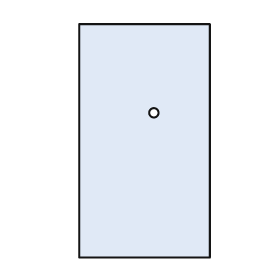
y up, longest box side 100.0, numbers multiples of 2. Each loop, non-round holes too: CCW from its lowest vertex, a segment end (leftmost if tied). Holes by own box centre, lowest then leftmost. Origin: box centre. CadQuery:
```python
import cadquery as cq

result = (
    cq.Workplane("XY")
    .moveTo(-28.0, -50.0)
    .lineTo(28.0, -50.0)
    .lineTo(28.0, 50.0)
    .lineTo(-28.0, 50.0)
    .close()
    .moveTo(4.0, 12.0)
    .circle(2.0)
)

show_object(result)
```